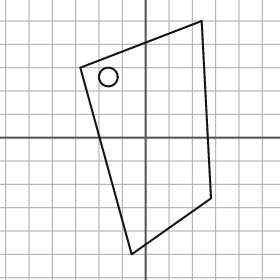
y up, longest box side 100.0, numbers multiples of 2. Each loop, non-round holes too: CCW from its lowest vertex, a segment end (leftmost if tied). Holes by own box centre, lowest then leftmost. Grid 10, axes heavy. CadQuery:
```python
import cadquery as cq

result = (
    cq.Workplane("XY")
    .moveTo(-6.0, -50.0)
    .lineTo(28.0, -26.0)
    .lineTo(24.0, 50.0)
    .lineTo(-28.0, 30.0)
    .close()
    .moveTo(-16.0, 26.0)
    .circle(4.0)
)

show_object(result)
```